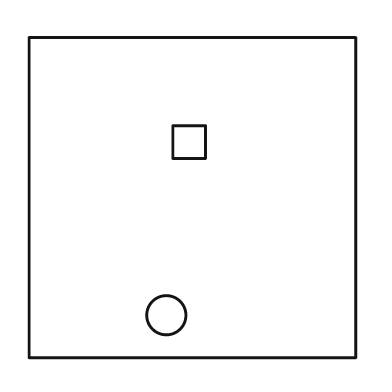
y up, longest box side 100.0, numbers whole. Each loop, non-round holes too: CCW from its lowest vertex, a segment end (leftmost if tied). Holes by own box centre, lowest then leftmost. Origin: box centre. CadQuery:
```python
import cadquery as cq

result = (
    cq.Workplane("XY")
    .moveTo(-50.0, -49.0)
    .lineTo(50.0, -49.0)
    .lineTo(50.0, 49.0)
    .lineTo(-50.0, 49.0)
    .close()
    .moveTo(-8.0, -36.0)
    .circle(6.0)
    .moveTo(-6.0, 12.0)
    .lineTo(4.0, 12.0)
    .lineTo(4.0, 22.0)
    .lineTo(-6.0, 22.0)
    .close()
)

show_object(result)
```